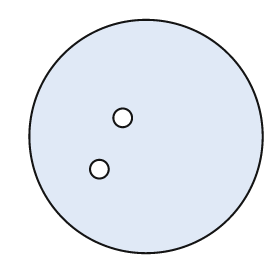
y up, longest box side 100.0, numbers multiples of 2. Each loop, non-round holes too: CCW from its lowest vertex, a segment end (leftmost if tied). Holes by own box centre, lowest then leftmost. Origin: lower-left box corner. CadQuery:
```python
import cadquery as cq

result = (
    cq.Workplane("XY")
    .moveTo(50.0, 50.0)
    .circle(50.0)
    .moveTo(30.0, 36.0)
    .circle(4.0)
    .moveTo(40.0, 58.0)
    .circle(4.0)
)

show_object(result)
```